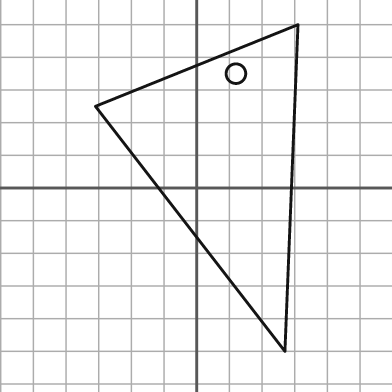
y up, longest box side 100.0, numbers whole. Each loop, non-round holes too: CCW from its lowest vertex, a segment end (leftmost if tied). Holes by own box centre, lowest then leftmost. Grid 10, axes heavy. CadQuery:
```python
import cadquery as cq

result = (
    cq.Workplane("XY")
    .moveTo(27.0, -50.0)
    .lineTo(31.0, 50.0)
    .lineTo(-31.0, 25.0)
    .close()
    .moveTo(12.0, 35.0)
    .circle(3.0)
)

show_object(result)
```